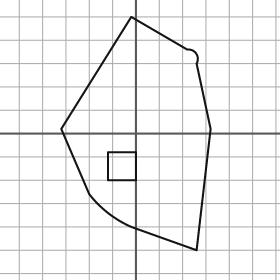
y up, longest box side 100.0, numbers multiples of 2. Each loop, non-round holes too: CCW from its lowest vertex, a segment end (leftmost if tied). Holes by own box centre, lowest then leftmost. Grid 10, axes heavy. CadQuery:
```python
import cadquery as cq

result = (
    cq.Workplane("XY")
    .moveTo(26.0, -50.0)
    .lineTo(32.0, 2.0)
    .lineTo(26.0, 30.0)
    .threePointArc((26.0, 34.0), (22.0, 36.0))
    .lineTo(-2.0, 50.0)
    .lineTo(-32.0, 2.0)
    .lineTo(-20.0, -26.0)
    .threePointArc((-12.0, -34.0), (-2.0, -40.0))
    .close()
    .moveTo(-12.0, -20.0)
    .lineTo(0.0, -20.0)
    .lineTo(0.0, -8.0)
    .lineTo(-12.0, -8.0)
    .close()
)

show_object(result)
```